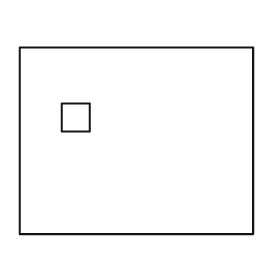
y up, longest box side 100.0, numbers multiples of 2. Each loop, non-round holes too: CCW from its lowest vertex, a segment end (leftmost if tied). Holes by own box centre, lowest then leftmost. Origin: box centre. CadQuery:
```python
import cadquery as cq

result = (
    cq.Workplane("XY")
    .moveTo(-50.0, -40.0)
    .lineTo(50.0, -40.0)
    .lineTo(50.0, 40.0)
    .lineTo(-50.0, 40.0)
    .close()
    .moveTo(-32.0, 4.0)
    .lineTo(-20.0, 4.0)
    .lineTo(-20.0, 16.0)
    .lineTo(-32.0, 16.0)
    .close()
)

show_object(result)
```